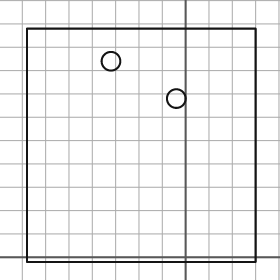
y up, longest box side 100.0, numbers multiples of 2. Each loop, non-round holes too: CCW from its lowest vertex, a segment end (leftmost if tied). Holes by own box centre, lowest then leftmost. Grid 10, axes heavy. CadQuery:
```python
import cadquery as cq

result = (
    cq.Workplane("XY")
    .moveTo(-68.0, -2.0)
    .lineTo(30.0, -2.0)
    .lineTo(30.0, 98.0)
    .lineTo(-68.0, 98.0)
    .close()
    .moveTo(-4.0, 68.0)
    .circle(4.0)
    .moveTo(-32.0, 84.0)
    .circle(4.0)
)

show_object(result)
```